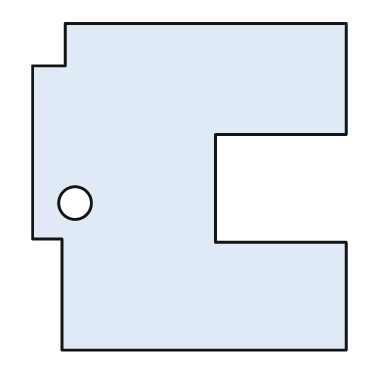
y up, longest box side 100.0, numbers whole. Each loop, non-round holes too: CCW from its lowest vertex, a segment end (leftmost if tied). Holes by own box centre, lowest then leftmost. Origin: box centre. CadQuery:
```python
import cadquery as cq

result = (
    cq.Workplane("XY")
    .moveTo(-39.0, -50.0)
    .lineTo(48.0, -50.0)
    .lineTo(48.0, -17.0)
    .lineTo(8.0, -17.0)
    .lineTo(8.0, 16.0)
    .lineTo(48.0, 16.0)
    .lineTo(48.0, 50.0)
    .lineTo(-38.0, 50.0)
    .lineTo(-38.0, 37.0)
    .lineTo(-48.0, 37.0)
    .lineTo(-48.0, -16.0)
    .lineTo(-39.0, -16.0)
    .close()
    .moveTo(-35.0, -5.0)
    .circle(5.0)
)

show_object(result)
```